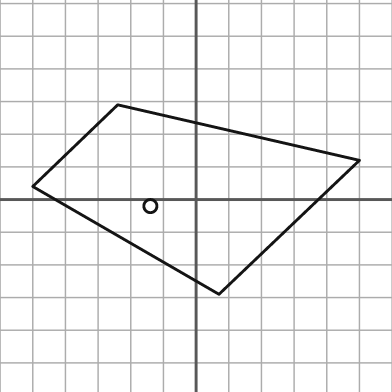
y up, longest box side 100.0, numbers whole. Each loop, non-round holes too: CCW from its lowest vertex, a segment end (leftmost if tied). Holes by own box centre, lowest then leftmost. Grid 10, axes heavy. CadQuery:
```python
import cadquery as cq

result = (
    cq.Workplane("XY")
    .moveTo(7.0, -29.0)
    .lineTo(50.0, 12.0)
    .lineTo(-24.0, 29.0)
    .lineTo(-50.0, 4.0)
    .close()
    .moveTo(-14.0, -2.0)
    .circle(2.0)
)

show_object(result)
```